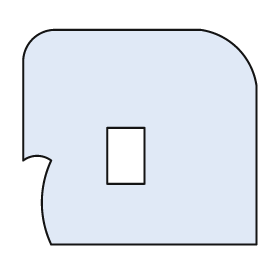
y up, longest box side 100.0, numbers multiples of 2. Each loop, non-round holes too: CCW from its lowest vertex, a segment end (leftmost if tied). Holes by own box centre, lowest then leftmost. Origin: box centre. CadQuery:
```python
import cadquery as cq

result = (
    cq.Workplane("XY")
    .moveTo(-38.0, -46.0)
    .lineTo(50.0, -46.0)
    .lineTo(50.0, 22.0)
    .threePointArc((42.0, 38.0), (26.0, 46.0))
    .lineTo(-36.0, 46.0)
    .threePointArc((-46.0, 42.0), (-50.0, 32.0))
    .lineTo(-50.0, -10.0)
    .threePointArc((-44.0, -8.0), (-38.0, -10.0))
    .threePointArc((-42.0, -28.0), (-38.0, -46.0))
    .close()
    .moveTo(-14.0, -20.0)
    .lineTo(2.0, -20.0)
    .lineTo(2.0, 4.0)
    .lineTo(-14.0, 4.0)
    .close()
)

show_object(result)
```